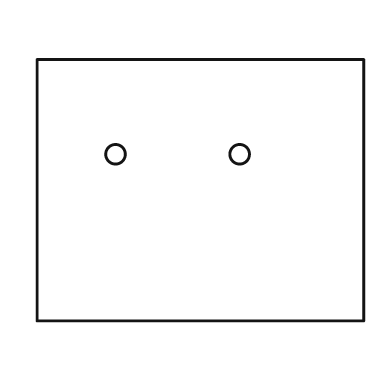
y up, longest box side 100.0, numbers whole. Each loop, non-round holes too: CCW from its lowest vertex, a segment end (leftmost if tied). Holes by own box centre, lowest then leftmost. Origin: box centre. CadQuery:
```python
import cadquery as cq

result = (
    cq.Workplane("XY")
    .moveTo(-50.0, -40.0)
    .lineTo(50.0, -40.0)
    .lineTo(50.0, 40.0)
    .lineTo(-50.0, 40.0)
    .close()
    .moveTo(-26.0, 11.0)
    .circle(3.0)
    .moveTo(12.0, 11.0)
    .circle(3.0)
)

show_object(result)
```